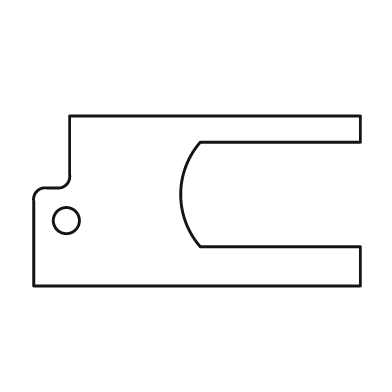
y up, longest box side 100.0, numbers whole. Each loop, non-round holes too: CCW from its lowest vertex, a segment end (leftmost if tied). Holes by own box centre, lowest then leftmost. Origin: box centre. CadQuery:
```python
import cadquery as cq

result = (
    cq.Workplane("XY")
    .moveTo(-50.0, -26.0)
    .lineTo(50.0, -26.0)
    .lineTo(50.0, -14.0)
    .lineTo(1.0, -14.0)
    .threePointArc((-5.0, 2.0), (1.0, 18.0))
    .lineTo(50.0, 18.0)
    .lineTo(50.0, 26.0)
    .lineTo(-39.0, 26.0)
    .lineTo(-39.0, 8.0)
    .threePointArc((-40.0, 5.0), (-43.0, 4.0))
    .lineTo(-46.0, 4.0)
    .threePointArc((-49.0, 3.0), (-50.0, 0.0))
    .close()
    .moveTo(-40.0, -6.0)
    .circle(4.0)
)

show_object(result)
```